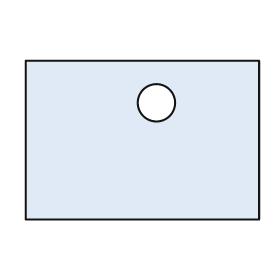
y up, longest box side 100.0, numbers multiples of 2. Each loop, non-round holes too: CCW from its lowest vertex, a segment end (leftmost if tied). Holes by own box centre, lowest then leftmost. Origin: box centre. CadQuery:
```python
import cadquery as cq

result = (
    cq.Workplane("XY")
    .moveTo(-50.0, -34.0)
    .lineTo(50.0, -34.0)
    .lineTo(50.0, 34.0)
    .lineTo(-50.0, 34.0)
    .close()
    .moveTo(6.0, 16.0)
    .circle(8.0)
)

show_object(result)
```